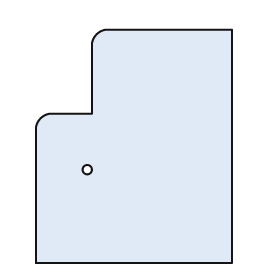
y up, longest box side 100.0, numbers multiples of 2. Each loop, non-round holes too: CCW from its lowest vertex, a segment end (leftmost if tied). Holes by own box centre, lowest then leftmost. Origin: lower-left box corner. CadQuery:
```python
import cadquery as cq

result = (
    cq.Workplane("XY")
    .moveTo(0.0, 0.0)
    .lineTo(84.0, 0.0)
    .lineTo(84.0, 100.0)
    .lineTo(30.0, 100.0)
    .threePointArc((26.0, 98.0), (24.0, 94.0))
    .lineTo(24.0, 64.0)
    .lineTo(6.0, 64.0)
    .threePointArc((2.0, 62.0), (0.0, 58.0))
    .close()
    .moveTo(22.0, 40.0)
    .circle(2.0)
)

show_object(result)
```